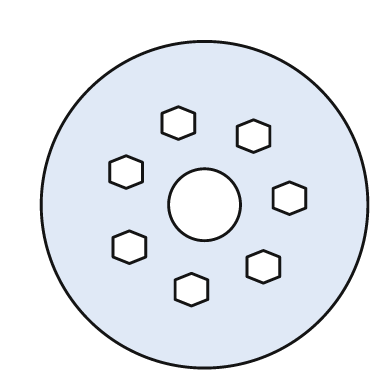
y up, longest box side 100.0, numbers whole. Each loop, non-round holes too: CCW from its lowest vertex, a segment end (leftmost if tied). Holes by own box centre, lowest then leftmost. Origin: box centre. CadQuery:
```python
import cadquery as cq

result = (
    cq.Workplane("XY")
    .moveTo(0.0, 0.0)
    .circle(50.0)
    .moveTo(-4.0, -31.0)
    .lineTo(1.0, -29.0)
    .lineTo(1.0, -23.0)
    .lineTo(-4.0, -21.0)
    .lineTo(-9.0, -23.0)
    .lineTo(-9.0, -29.0)
    .close()
    .moveTo(18.0, -24.0)
    .lineTo(23.0, -22.0)
    .lineTo(23.0, -16.0)
    .lineTo(18.0, -14.0)
    .lineTo(13.0, -16.0)
    .lineTo(13.0, -22.0)
    .close()
    .moveTo(-23.0, -18.0)
    .lineTo(-18.0, -16.0)
    .lineTo(-18.0, -10.0)
    .lineTo(-23.0, -8.0)
    .lineTo(-28.0, -10.0)
    .lineTo(-28.0, -16.0)
    .close()
    .moveTo(0.0, 0.0)
    .circle(11.0)
    .moveTo(26.0, -3.0)
    .lineTo(31.0, -1.0)
    .lineTo(31.0, 5.0)
    .lineTo(26.0, 7.0)
    .lineTo(21.0, 5.0)
    .lineTo(21.0, -1.0)
    .close()
    .moveTo(-24.0, 5.0)
    .lineTo(-19.0, 7.0)
    .lineTo(-19.0, 13.0)
    .lineTo(-24.0, 15.0)
    .lineTo(-29.0, 13.0)
    .lineTo(-29.0, 7.0)
    .close()
    .moveTo(15.0, 16.0)
    .lineTo(20.0, 18.0)
    .lineTo(20.0, 24.0)
    .lineTo(15.0, 26.0)
    .lineTo(10.0, 24.0)
    .lineTo(10.0, 18.0)
    .close()
    .moveTo(-8.0, 20.0)
    .lineTo(-3.0, 22.0)
    .lineTo(-3.0, 28.0)
    .lineTo(-8.0, 30.0)
    .lineTo(-13.0, 28.0)
    .lineTo(-13.0, 22.0)
    .close()
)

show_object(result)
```